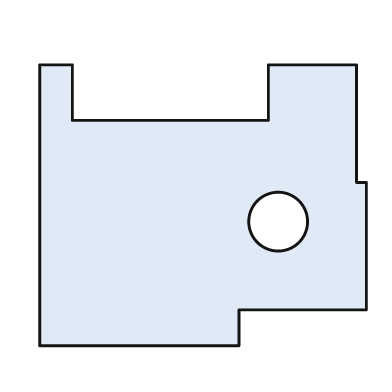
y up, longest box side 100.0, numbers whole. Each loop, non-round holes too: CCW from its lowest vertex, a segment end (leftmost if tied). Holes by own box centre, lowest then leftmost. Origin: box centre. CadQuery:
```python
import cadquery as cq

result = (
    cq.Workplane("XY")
    .moveTo(-50.0, -43.0)
    .lineTo(11.0, -43.0)
    .lineTo(11.0, -32.0)
    .lineTo(50.0, -32.0)
    .lineTo(50.0, 7.0)
    .lineTo(47.0, 7.0)
    .lineTo(47.0, 43.0)
    .lineTo(20.0, 43.0)
    .lineTo(20.0, 26.0)
    .lineTo(-40.0, 26.0)
    .lineTo(-40.0, 43.0)
    .lineTo(-50.0, 43.0)
    .close()
    .moveTo(23.0, -5.0)
    .circle(9.0)
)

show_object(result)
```